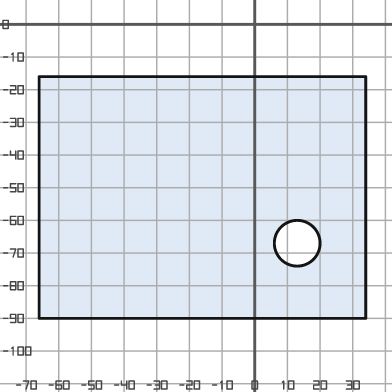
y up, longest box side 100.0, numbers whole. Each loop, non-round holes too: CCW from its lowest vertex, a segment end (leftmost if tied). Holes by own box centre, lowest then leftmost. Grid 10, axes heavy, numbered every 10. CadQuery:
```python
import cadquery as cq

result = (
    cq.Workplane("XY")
    .moveTo(-66.0, -90.0)
    .lineTo(34.0, -90.0)
    .lineTo(34.0, -16.0)
    .lineTo(-66.0, -16.0)
    .close()
    .moveTo(13.0, -67.0)
    .circle(7.0)
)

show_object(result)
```